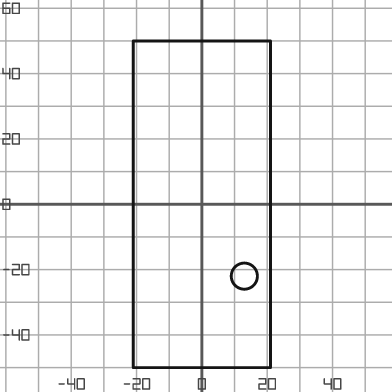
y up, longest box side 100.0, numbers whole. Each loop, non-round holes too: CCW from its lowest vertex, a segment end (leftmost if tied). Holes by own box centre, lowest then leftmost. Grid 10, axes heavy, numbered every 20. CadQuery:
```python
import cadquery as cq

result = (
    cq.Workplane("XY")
    .moveTo(-21.0, -50.0)
    .lineTo(21.0, -50.0)
    .lineTo(21.0, 50.0)
    .lineTo(-21.0, 50.0)
    .close()
    .moveTo(13.0, -22.0)
    .circle(4.0)
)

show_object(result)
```